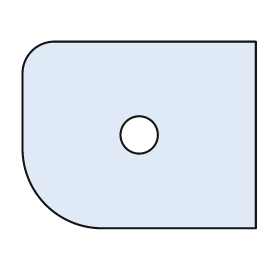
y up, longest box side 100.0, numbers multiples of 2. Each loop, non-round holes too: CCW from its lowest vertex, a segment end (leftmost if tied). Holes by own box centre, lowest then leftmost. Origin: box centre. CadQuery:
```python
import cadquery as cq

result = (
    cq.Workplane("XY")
    .moveTo(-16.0, -40.0)
    .lineTo(50.0, -40.0)
    .lineTo(50.0, 40.0)
    .lineTo(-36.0, 40.0)
    .threePointArc((-46.0, 36.0), (-50.0, 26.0))
    .lineTo(-50.0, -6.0)
    .threePointArc((-40.0, -30.0), (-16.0, -40.0))
    .close()
    .moveTo(0.0, 0.0)
    .circle(8.0)
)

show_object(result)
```